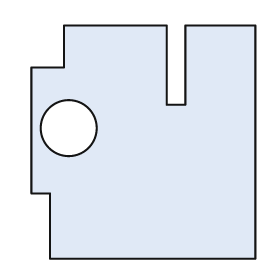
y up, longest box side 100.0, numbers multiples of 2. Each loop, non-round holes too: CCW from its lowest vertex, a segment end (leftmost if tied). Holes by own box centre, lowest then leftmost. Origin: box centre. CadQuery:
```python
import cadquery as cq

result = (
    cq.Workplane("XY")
    .moveTo(-40.0, -50.0)
    .lineTo(48.0, -50.0)
    .lineTo(48.0, 50.0)
    .lineTo(18.0, 50.0)
    .lineTo(18.0, 16.0)
    .lineTo(10.0, 16.0)
    .lineTo(10.0, 50.0)
    .lineTo(-34.0, 50.0)
    .lineTo(-34.0, 32.0)
    .lineTo(-48.0, 32.0)
    .lineTo(-48.0, -22.0)
    .lineTo(-40.0, -22.0)
    .close()
    .moveTo(-32.0, 6.0)
    .circle(12.0)
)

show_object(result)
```